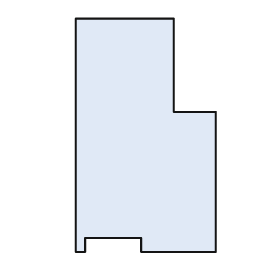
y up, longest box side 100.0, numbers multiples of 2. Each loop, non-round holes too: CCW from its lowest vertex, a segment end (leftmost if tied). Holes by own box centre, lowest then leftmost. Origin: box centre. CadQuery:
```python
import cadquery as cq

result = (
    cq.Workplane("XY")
    .moveTo(-30.0, -50.0)
    .lineTo(-26.0, -50.0)
    .lineTo(-26.0, -44.0)
    .lineTo(-2.0, -44.0)
    .lineTo(-2.0, -50.0)
    .lineTo(30.0, -50.0)
    .lineTo(30.0, 10.0)
    .lineTo(12.0, 10.0)
    .lineTo(12.0, 50.0)
    .lineTo(-30.0, 50.0)
    .close()
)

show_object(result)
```